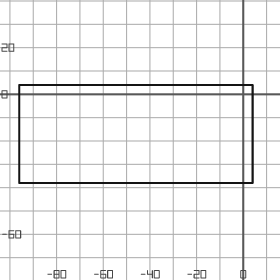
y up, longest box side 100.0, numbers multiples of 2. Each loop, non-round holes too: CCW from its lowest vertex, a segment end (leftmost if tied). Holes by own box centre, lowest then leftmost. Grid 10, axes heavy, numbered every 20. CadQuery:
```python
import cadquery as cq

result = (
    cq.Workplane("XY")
    .moveTo(-96.0, -38.0)
    .lineTo(4.0, -38.0)
    .lineTo(4.0, 4.0)
    .lineTo(-96.0, 4.0)
    .close()
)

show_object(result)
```